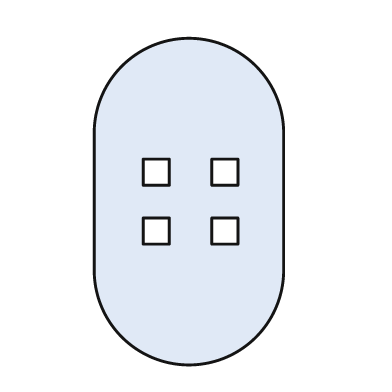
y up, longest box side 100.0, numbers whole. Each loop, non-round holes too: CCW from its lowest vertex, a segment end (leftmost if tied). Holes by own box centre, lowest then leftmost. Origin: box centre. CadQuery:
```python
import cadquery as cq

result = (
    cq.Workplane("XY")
    .moveTo(-29.0, -21.0)
    .threePointArc((0.0, -50.0), (29.0, -21.0))
    .lineTo(29.0, 21.0)
    .threePointArc((0.0, 50.0), (-29.0, 21.0))
    .close()
    .moveTo(-14.0, -13.0)
    .lineTo(-6.0, -13.0)
    .lineTo(-6.0, -5.0)
    .lineTo(-14.0, -5.0)
    .close()
    .moveTo(7.0, -13.0)
    .lineTo(15.0, -13.0)
    .lineTo(15.0, -5.0)
    .lineTo(7.0, -5.0)
    .close()
    .moveTo(-14.0, 5.0)
    .lineTo(-6.0, 5.0)
    .lineTo(-6.0, 13.0)
    .lineTo(-14.0, 13.0)
    .close()
    .moveTo(7.0, 5.0)
    .lineTo(15.0, 5.0)
    .lineTo(15.0, 13.0)
    .lineTo(7.0, 13.0)
    .close()
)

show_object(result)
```